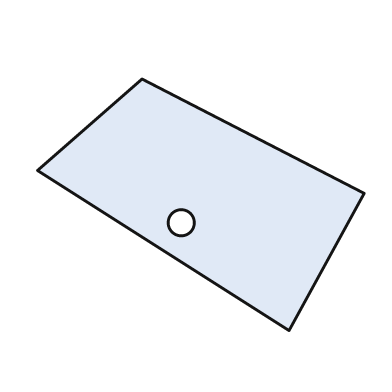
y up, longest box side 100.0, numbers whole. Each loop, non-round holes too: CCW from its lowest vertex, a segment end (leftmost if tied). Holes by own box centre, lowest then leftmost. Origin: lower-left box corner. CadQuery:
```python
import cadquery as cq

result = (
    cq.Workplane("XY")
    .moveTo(77.0, 0.0)
    .lineTo(100.0, 42.0)
    .lineTo(32.0, 77.0)
    .lineTo(0.0, 49.0)
    .close()
    .moveTo(44.0, 33.0)
    .circle(4.0)
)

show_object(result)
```